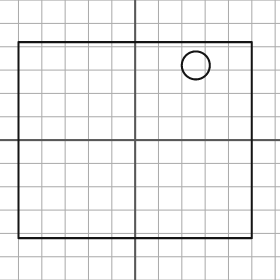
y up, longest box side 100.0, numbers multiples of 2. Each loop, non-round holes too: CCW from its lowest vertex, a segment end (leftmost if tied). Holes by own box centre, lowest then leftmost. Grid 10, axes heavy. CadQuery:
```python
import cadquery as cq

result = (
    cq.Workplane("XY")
    .moveTo(-50.0, -42.0)
    .lineTo(50.0, -42.0)
    .lineTo(50.0, 42.0)
    .lineTo(-50.0, 42.0)
    .close()
    .moveTo(26.0, 32.0)
    .circle(6.0)
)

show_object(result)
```